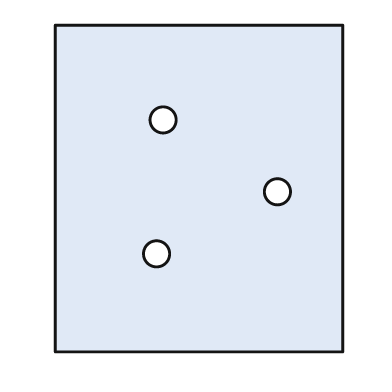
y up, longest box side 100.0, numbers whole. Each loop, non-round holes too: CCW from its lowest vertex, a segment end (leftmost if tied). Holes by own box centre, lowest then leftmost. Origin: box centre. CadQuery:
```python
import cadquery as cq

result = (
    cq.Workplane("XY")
    .moveTo(-44.0, -50.0)
    .lineTo(44.0, -50.0)
    .lineTo(44.0, 50.0)
    .lineTo(-44.0, 50.0)
    .close()
    .moveTo(-13.0, -20.0)
    .circle(4.0)
    .moveTo(24.0, -1.0)
    .circle(4.0)
    .moveTo(-11.0, 21.0)
    .circle(4.0)
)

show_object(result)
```